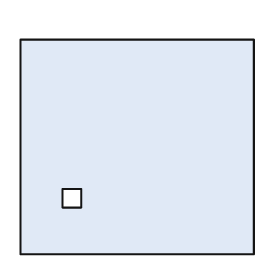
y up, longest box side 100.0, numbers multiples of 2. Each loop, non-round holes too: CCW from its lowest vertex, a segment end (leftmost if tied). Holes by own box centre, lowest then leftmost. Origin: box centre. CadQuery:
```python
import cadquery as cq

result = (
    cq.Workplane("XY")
    .moveTo(-50.0, -46.0)
    .lineTo(50.0, -46.0)
    .lineTo(50.0, 46.0)
    .lineTo(-50.0, 46.0)
    .close()
    .moveTo(-32.0, -26.0)
    .lineTo(-24.0, -26.0)
    .lineTo(-24.0, -18.0)
    .lineTo(-32.0, -18.0)
    .close()
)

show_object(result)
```